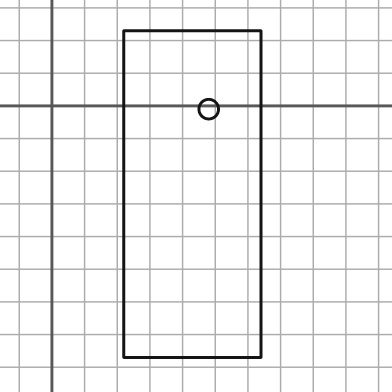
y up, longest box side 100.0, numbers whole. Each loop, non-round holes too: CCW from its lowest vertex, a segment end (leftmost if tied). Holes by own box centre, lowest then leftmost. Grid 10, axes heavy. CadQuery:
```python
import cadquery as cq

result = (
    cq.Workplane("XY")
    .moveTo(22.0, -77.0)
    .lineTo(64.0, -77.0)
    .lineTo(64.0, 23.0)
    .lineTo(22.0, 23.0)
    .close()
    .moveTo(48.0, -1.0)
    .circle(3.0)
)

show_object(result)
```